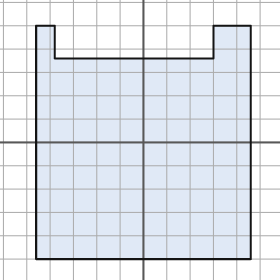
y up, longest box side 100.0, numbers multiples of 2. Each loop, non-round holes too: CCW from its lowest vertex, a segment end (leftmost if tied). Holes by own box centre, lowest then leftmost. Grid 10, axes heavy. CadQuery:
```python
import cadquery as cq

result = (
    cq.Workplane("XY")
    .moveTo(-46.0, -50.0)
    .lineTo(46.0, -50.0)
    .lineTo(46.0, 50.0)
    .lineTo(30.0, 50.0)
    .lineTo(30.0, 36.0)
    .lineTo(-38.0, 36.0)
    .lineTo(-38.0, 50.0)
    .lineTo(-46.0, 50.0)
    .close()
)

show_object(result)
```